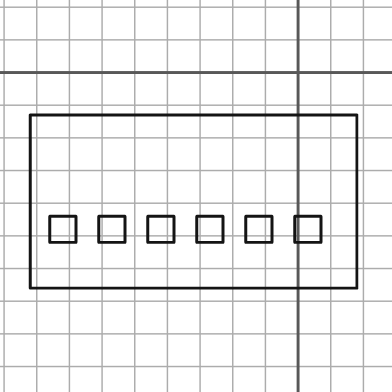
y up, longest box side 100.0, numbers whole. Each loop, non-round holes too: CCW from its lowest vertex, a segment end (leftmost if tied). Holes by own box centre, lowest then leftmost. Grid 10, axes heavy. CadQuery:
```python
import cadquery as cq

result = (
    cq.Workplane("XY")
    .moveTo(-82.0, -66.0)
    .lineTo(18.0, -66.0)
    .lineTo(18.0, -13.0)
    .lineTo(-82.0, -13.0)
    .close()
    .moveTo(-76.0, -52.0)
    .lineTo(-68.0, -52.0)
    .lineTo(-68.0, -44.0)
    .lineTo(-76.0, -44.0)
    .close()
    .moveTo(-61.0, -52.0)
    .lineTo(-53.0, -52.0)
    .lineTo(-53.0, -44.0)
    .lineTo(-61.0, -44.0)
    .close()
    .moveTo(-46.0, -52.0)
    .lineTo(-38.0, -52.0)
    .lineTo(-38.0, -44.0)
    .lineTo(-46.0, -44.0)
    .close()
    .moveTo(-31.0, -52.0)
    .lineTo(-23.0, -52.0)
    .lineTo(-23.0, -44.0)
    .lineTo(-31.0, -44.0)
    .close()
    .moveTo(-16.0, -52.0)
    .lineTo(-8.0, -52.0)
    .lineTo(-8.0, -44.0)
    .lineTo(-16.0, -44.0)
    .close()
    .moveTo(-1.0, -52.0)
    .lineTo(7.0, -52.0)
    .lineTo(7.0, -44.0)
    .lineTo(-1.0, -44.0)
    .close()
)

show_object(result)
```